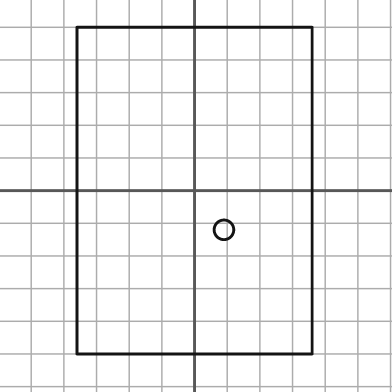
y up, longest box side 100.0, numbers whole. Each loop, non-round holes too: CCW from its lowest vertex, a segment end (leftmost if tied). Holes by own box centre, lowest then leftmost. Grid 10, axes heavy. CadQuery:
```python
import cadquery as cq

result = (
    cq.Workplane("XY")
    .moveTo(-36.0, -50.0)
    .lineTo(36.0, -50.0)
    .lineTo(36.0, 50.0)
    .lineTo(-36.0, 50.0)
    .close()
    .moveTo(9.0, -12.0)
    .circle(3.0)
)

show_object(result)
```